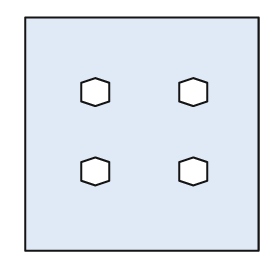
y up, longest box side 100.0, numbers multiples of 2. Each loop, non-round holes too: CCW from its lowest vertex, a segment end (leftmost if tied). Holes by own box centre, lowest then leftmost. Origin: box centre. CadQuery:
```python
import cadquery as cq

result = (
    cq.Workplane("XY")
    .moveTo(-50.0, -50.0)
    .lineTo(50.0, -50.0)
    .lineTo(50.0, 50.0)
    .lineTo(-50.0, 50.0)
    .close()
    .moveTo(-20.0, -22.0)
    .lineTo(-14.0, -20.0)
    .lineTo(-14.0, -12.0)
    .lineTo(-20.0, -10.0)
    .lineTo(-26.0, -12.0)
    .lineTo(-26.0, -20.0)
    .close()
    .moveTo(22.0, -22.0)
    .lineTo(28.0, -20.0)
    .lineTo(28.0, -12.0)
    .lineTo(22.0, -10.0)
    .lineTo(16.0, -12.0)
    .lineTo(16.0, -20.0)
    .close()
    .moveTo(-20.0, 12.0)
    .lineTo(-14.0, 14.0)
    .lineTo(-14.0, 22.0)
    .lineTo(-20.0, 24.0)
    .lineTo(-26.0, 22.0)
    .lineTo(-26.0, 14.0)
    .close()
    .moveTo(22.0, 12.0)
    .lineTo(28.0, 14.0)
    .lineTo(28.0, 22.0)
    .lineTo(22.0, 24.0)
    .lineTo(16.0, 22.0)
    .lineTo(16.0, 14.0)
    .close()
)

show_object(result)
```